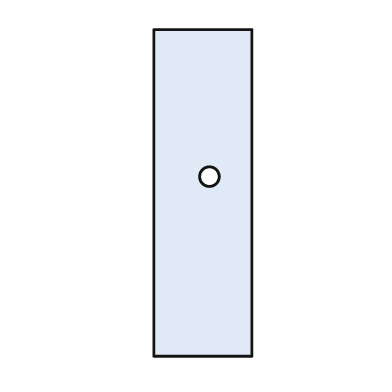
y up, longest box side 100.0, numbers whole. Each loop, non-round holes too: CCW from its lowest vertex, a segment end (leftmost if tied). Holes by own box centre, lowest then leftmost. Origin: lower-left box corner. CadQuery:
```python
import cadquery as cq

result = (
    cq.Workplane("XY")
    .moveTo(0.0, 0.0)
    .lineTo(30.0, 0.0)
    .lineTo(30.0, 100.0)
    .lineTo(0.0, 100.0)
    .close()
    .moveTo(17.0, 55.0)
    .circle(3.0)
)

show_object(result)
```